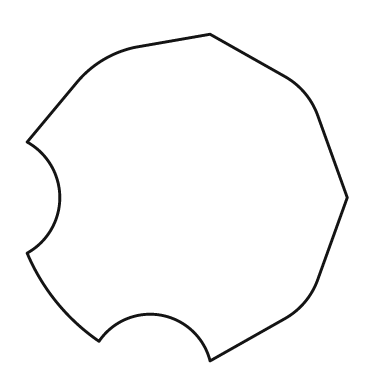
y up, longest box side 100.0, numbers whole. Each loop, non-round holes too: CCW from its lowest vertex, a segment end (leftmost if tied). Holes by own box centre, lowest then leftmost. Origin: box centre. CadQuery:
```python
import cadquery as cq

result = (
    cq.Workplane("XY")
    .moveTo(7.0, -50.0)
    .lineTo(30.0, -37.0)
    .threePointArc((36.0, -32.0), (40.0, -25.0))
    .lineTo(49.0, 0.0)
    .lineTo(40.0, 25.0)
    .threePointArc((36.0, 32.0), (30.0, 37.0))
    .lineTo(7.0, 50.0)
    .lineTo(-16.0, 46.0)
    .threePointArc((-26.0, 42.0), (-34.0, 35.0))
    .lineTo(-49.0, 17.0)
    .threePointArc((-39.0, 0.0), (-49.0, -17.0))
    .threePointArc((-40.0, -32.0), (-27.0, -44.0))
    .threePointArc((-8.0, -36.0), (7.0, -50.0))
    .close()
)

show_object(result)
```